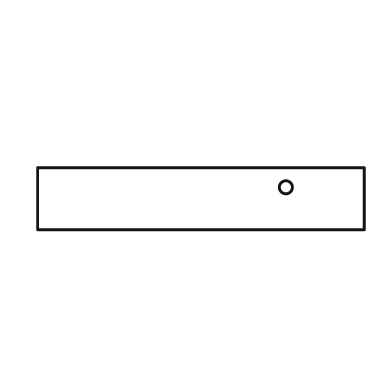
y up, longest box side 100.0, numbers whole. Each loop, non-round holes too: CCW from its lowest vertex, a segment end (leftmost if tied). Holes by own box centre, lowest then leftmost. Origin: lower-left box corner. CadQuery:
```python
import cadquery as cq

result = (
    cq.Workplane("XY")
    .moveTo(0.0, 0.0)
    .lineTo(100.0, 0.0)
    .lineTo(100.0, 19.0)
    .lineTo(0.0, 19.0)
    .close()
    .moveTo(76.0, 13.0)
    .circle(2.0)
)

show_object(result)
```